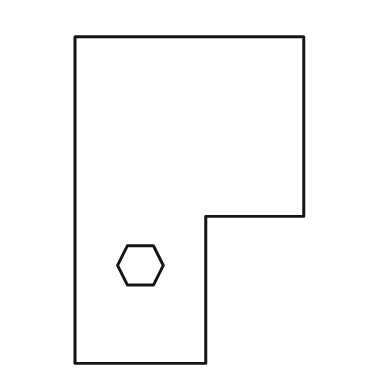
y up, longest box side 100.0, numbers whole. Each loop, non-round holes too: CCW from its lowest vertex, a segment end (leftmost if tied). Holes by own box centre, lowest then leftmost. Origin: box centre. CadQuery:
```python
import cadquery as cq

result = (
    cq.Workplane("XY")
    .moveTo(-35.0, -50.0)
    .lineTo(5.0, -50.0)
    .lineTo(5.0, -5.0)
    .lineTo(35.0, -5.0)
    .lineTo(35.0, 50.0)
    .lineTo(-35.0, 50.0)
    .close()
    .moveTo(-19.0, -26.0)
    .lineTo(-11.0, -26.0)
    .lineTo(-8.0, -20.0)
    .lineTo(-11.0, -14.0)
    .lineTo(-19.0, -14.0)
    .lineTo(-22.0, -20.0)
    .close()
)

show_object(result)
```